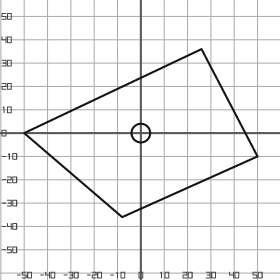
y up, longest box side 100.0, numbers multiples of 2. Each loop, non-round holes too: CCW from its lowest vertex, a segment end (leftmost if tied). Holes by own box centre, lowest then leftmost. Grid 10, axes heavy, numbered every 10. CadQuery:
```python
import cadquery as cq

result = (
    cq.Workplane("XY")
    .moveTo(-8.0, -36.0)
    .lineTo(50.0, -10.0)
    .lineTo(26.0, 36.0)
    .lineTo(-50.0, 0.0)
    .close()
    .moveTo(0.0, 0.0)
    .circle(4.0)
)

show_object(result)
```